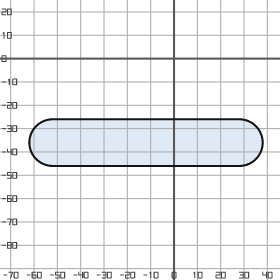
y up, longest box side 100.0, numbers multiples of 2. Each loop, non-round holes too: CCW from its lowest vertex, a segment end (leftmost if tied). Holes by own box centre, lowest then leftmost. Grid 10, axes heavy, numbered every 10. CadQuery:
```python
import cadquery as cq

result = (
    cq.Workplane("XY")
    .moveTo(-52.0, -46.0)
    .lineTo(28.0, -46.0)
    .threePointArc((38.0, -36.0), (28.0, -26.0))
    .lineTo(-52.0, -26.0)
    .threePointArc((-62.0, -36.0), (-52.0, -46.0))
    .close()
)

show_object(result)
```